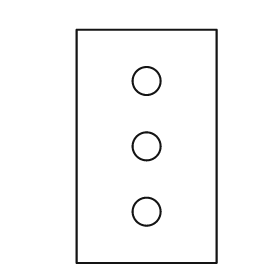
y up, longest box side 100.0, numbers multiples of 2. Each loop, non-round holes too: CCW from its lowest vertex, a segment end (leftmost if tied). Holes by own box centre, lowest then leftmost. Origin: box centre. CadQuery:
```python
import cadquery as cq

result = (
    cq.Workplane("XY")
    .moveTo(-30.0, -50.0)
    .lineTo(30.0, -50.0)
    .lineTo(30.0, 50.0)
    .lineTo(-30.0, 50.0)
    .close()
    .moveTo(0.0, -28.0)
    .circle(6.0)
    .moveTo(0.0, 0.0)
    .circle(6.0)
    .moveTo(0.0, 28.0)
    .circle(6.0)
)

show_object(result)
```